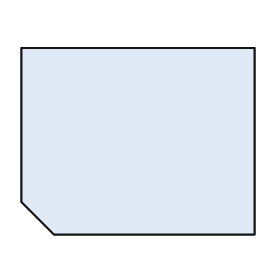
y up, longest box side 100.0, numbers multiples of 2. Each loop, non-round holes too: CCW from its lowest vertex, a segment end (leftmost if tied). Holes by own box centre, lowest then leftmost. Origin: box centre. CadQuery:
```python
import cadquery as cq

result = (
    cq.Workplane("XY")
    .moveTo(-36.0, -40.0)
    .lineTo(50.0, -40.0)
    .lineTo(50.0, 40.0)
    .lineTo(-50.0, 40.0)
    .lineTo(-50.0, -26.0)
    .close()
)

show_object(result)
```